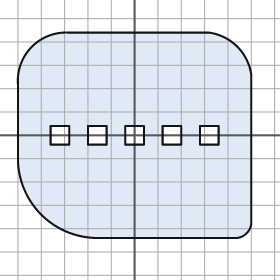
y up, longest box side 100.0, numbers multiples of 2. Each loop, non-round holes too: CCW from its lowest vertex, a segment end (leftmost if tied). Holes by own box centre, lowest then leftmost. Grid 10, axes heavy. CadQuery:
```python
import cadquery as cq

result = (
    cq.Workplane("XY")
    .moveTo(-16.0, -44.0)
    .lineTo(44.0, -44.0)
    .threePointArc((48.0, -42.0), (50.0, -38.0))
    .lineTo(50.0, 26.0)
    .threePointArc((44.0, 38.0), (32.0, 44.0))
    .lineTo(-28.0, 44.0)
    .threePointArc((-44.0, 38.0), (-50.0, 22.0))
    .lineTo(-50.0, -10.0)
    .threePointArc((-40.0, -34.0), (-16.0, -44.0))
    .close()
    .moveTo(-36.0, -4.0)
    .lineTo(-28.0, -4.0)
    .lineTo(-28.0, 4.0)
    .lineTo(-36.0, 4.0)
    .close()
    .moveTo(-20.0, -4.0)
    .lineTo(-12.0, -4.0)
    .lineTo(-12.0, 4.0)
    .lineTo(-20.0, 4.0)
    .close()
    .moveTo(-4.0, -4.0)
    .lineTo(4.0, -4.0)
    .lineTo(4.0, 4.0)
    .lineTo(-4.0, 4.0)
    .close()
    .moveTo(12.0, -4.0)
    .lineTo(20.0, -4.0)
    .lineTo(20.0, 4.0)
    .lineTo(12.0, 4.0)
    .close()
    .moveTo(28.0, -4.0)
    .lineTo(36.0, -4.0)
    .lineTo(36.0, 4.0)
    .lineTo(28.0, 4.0)
    .close()
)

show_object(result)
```